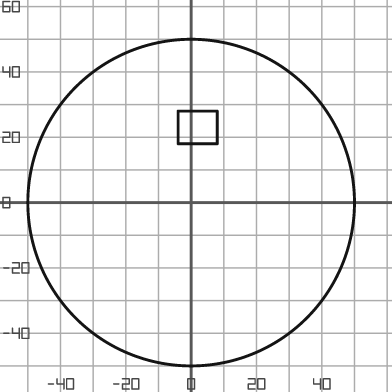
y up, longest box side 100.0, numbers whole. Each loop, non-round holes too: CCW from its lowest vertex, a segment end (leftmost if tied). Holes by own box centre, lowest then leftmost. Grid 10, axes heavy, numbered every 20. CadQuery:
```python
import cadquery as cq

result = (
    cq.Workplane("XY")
    .moveTo(0.0, 0.0)
    .circle(50.0)
    .moveTo(-4.0, 18.0)
    .lineTo(8.0, 18.0)
    .lineTo(8.0, 28.0)
    .lineTo(-4.0, 28.0)
    .close()
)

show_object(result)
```